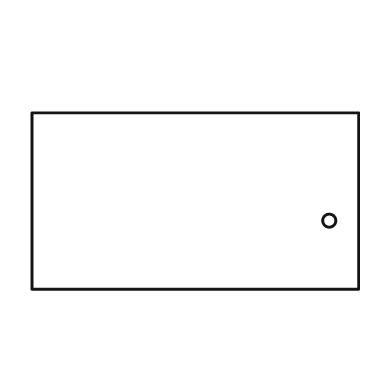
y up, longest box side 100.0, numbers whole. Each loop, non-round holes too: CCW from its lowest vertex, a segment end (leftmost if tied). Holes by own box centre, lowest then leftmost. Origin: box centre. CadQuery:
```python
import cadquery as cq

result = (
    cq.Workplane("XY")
    .moveTo(-50.0, -27.0)
    .lineTo(50.0, -27.0)
    .lineTo(50.0, 27.0)
    .lineTo(-50.0, 27.0)
    .close()
    .moveTo(41.0, -6.0)
    .circle(2.0)
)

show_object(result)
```